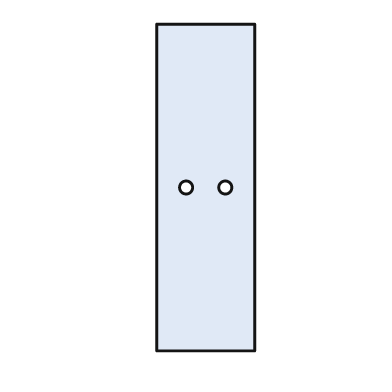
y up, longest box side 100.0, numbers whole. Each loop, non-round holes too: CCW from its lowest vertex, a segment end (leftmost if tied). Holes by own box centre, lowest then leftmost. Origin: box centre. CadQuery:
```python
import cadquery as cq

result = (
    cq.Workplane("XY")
    .moveTo(-15.0, -50.0)
    .lineTo(15.0, -50.0)
    .lineTo(15.0, 50.0)
    .lineTo(-15.0, 50.0)
    .close()
    .moveTo(-6.0, 0.0)
    .circle(2.0)
    .moveTo(6.0, 0.0)
    .circle(2.0)
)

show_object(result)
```